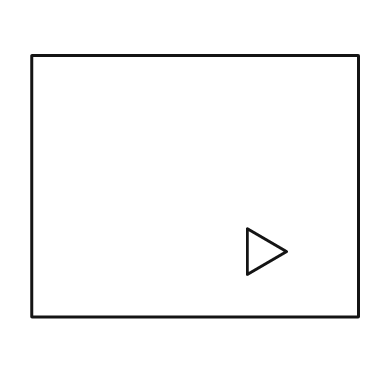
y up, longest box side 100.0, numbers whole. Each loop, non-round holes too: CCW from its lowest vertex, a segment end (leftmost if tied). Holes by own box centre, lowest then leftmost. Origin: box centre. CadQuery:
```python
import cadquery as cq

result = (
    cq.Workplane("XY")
    .moveTo(-50.0, -40.0)
    .lineTo(50.0, -40.0)
    .lineTo(50.0, 40.0)
    .lineTo(-50.0, 40.0)
    .close()
    .moveTo(16.0, -27.0)
    .lineTo(28.0, -20.0)
    .lineTo(16.0, -13.0)
    .close()
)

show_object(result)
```